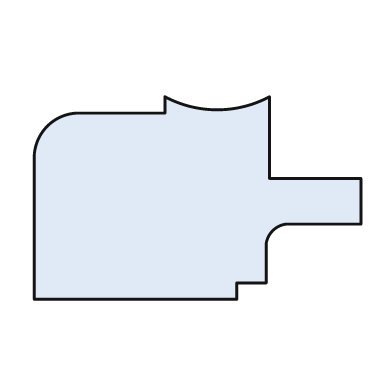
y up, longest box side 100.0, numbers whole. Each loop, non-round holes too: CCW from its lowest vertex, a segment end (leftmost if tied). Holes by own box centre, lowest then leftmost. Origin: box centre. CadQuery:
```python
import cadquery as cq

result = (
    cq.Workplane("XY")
    .moveTo(-50.0, -31.0)
    .lineTo(12.0, -31.0)
    .lineTo(12.0, -26.0)
    .lineTo(21.0, -26.0)
    .lineTo(21.0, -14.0)
    .threePointArc((23.0, -10.0), (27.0, -8.0))
    .lineTo(50.0, -8.0)
    .lineTo(50.0, 6.0)
    .lineTo(22.0, 6.0)
    .lineTo(22.0, 31.0)
    .threePointArc((6.0, 27.0), (-10.0, 31.0))
    .lineTo(-10.0, 26.0)
    .lineTo(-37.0, 26.0)
    .threePointArc((-46.0, 22.0), (-50.0, 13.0))
    .close()
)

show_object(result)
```